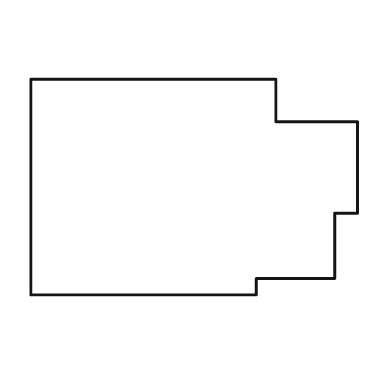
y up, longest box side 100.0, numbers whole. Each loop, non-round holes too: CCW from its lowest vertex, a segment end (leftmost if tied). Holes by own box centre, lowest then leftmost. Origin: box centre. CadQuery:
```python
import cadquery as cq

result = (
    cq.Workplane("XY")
    .moveTo(-50.0, -33.0)
    .lineTo(19.0, -33.0)
    .lineTo(19.0, -28.0)
    .lineTo(43.0, -28.0)
    .lineTo(43.0, -8.0)
    .lineTo(50.0, -8.0)
    .lineTo(50.0, 20.0)
    .lineTo(25.0, 20.0)
    .lineTo(25.0, 33.0)
    .lineTo(-50.0, 33.0)
    .close()
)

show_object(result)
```